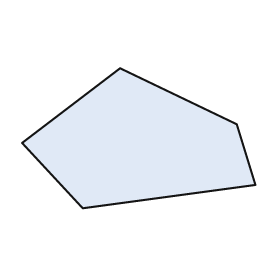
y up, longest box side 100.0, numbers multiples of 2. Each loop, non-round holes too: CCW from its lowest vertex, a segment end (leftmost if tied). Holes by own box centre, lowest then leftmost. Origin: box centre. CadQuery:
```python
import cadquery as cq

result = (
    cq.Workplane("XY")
    .moveTo(-24.0, -30.0)
    .lineTo(50.0, -20.0)
    .lineTo(42.0, 6.0)
    .lineTo(-8.0, 30.0)
    .lineTo(-50.0, -2.0)
    .close()
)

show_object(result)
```